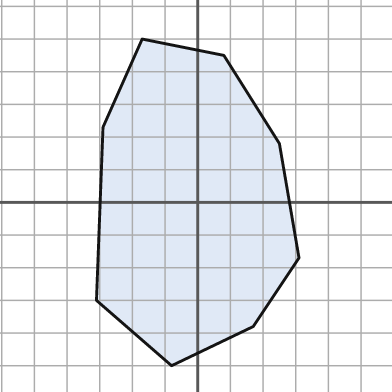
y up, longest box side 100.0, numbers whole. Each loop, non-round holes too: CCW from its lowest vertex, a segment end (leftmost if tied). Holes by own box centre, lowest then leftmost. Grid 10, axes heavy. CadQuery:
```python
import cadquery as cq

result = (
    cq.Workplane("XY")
    .moveTo(-8.0, -50.0)
    .lineTo(17.0, -38.0)
    .lineTo(31.0, -17.0)
    .lineTo(25.0, 18.0)
    .lineTo(8.0, 45.0)
    .lineTo(-17.0, 50.0)
    .lineTo(-29.0, 23.0)
    .lineTo(-31.0, -30.0)
    .close()
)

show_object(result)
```